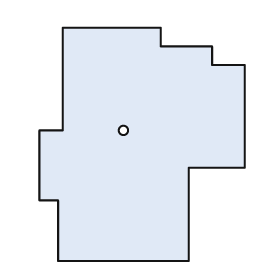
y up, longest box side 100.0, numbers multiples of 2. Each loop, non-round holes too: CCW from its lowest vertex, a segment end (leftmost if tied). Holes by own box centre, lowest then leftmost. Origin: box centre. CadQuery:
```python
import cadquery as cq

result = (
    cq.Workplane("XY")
    .moveTo(-36.0, -50.0)
    .lineTo(20.0, -50.0)
    .lineTo(20.0, -10.0)
    .lineTo(44.0, -10.0)
    .lineTo(44.0, 34.0)
    .lineTo(30.0, 34.0)
    .lineTo(30.0, 42.0)
    .lineTo(8.0, 42.0)
    .lineTo(8.0, 50.0)
    .lineTo(-34.0, 50.0)
    .lineTo(-34.0, 6.0)
    .lineTo(-44.0, 6.0)
    .lineTo(-44.0, -24.0)
    .lineTo(-36.0, -24.0)
    .close()
    .moveTo(-8.0, 6.0)
    .circle(2.0)
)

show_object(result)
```